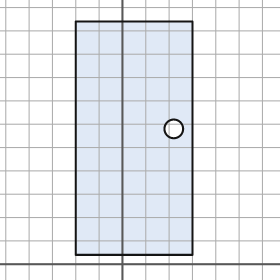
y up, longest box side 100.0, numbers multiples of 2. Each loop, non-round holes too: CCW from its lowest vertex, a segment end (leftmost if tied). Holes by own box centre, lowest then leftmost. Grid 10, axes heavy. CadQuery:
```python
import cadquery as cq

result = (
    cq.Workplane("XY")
    .moveTo(-20.0, 4.0)
    .lineTo(30.0, 4.0)
    .lineTo(30.0, 104.0)
    .lineTo(-20.0, 104.0)
    .close()
    .moveTo(22.0, 58.0)
    .circle(4.0)
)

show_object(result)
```